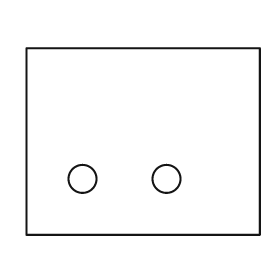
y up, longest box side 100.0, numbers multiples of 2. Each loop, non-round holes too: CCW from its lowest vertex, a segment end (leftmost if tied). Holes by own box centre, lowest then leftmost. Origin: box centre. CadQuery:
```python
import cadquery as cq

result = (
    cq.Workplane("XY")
    .moveTo(-50.0, -40.0)
    .lineTo(50.0, -40.0)
    .lineTo(50.0, 40.0)
    .lineTo(-50.0, 40.0)
    .close()
    .moveTo(-26.0, -16.0)
    .circle(6.0)
    .moveTo(10.0, -16.0)
    .circle(6.0)
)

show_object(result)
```